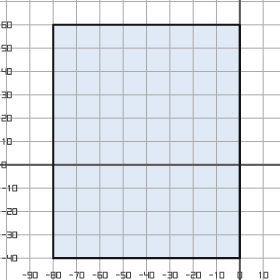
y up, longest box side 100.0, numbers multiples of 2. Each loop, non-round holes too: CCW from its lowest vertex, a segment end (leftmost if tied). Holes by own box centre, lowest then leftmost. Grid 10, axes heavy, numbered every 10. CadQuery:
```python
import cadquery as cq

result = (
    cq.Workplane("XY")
    .moveTo(-80.0, -40.0)
    .lineTo(0.0, -40.0)
    .lineTo(0.0, 60.0)
    .lineTo(-80.0, 60.0)
    .close()
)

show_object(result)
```